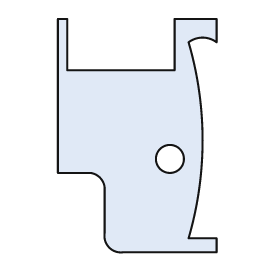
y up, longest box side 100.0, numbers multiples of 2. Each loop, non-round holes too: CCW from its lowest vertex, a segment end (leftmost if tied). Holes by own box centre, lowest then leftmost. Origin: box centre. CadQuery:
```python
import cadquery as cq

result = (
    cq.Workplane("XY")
    .moveTo(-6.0, -50.0)
    .lineTo(34.0, -50.0)
    .lineTo(34.0, -44.0)
    .lineTo(22.0, -44.0)
    .threePointArc((28.0, -2.0), (22.0, 40.0))
    .threePointArc((28.0, 42.0), (34.0, 40.0))
    .lineTo(34.0, 50.0)
    .lineTo(16.0, 50.0)
    .lineTo(16.0, 28.0)
    .lineTo(-30.0, 28.0)
    .lineTo(-30.0, 50.0)
    .lineTo(-34.0, 50.0)
    .lineTo(-34.0, -16.0)
    .lineTo(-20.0, -16.0)
    .threePointArc((-16.0, -18.0), (-14.0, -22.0))
    .lineTo(-14.0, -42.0)
    .threePointArc((-12.0, -48.0), (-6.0, -50.0))
    .close()
    .moveTo(14.0, -10.0)
    .circle(6.0)
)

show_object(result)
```